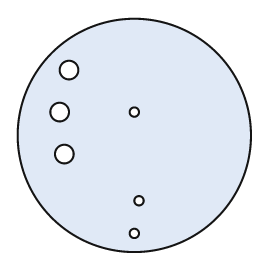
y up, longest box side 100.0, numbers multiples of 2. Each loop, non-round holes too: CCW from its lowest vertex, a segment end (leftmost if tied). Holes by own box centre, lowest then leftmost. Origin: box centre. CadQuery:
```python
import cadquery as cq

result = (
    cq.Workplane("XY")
    .moveTo(0.0, 0.0)
    .circle(50.0)
    .moveTo(0.0, -42.0)
    .circle(2.0)
    .moveTo(2.0, -28.0)
    .circle(2.0)
    .moveTo(-30.0, -8.0)
    .circle(4.0)
    .moveTo(-32.0, 10.0)
    .circle(4.0)
    .moveTo(0.0, 10.0)
    .circle(2.0)
    .moveTo(-28.0, 28.0)
    .circle(4.0)
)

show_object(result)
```